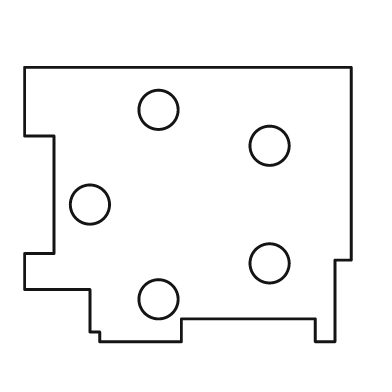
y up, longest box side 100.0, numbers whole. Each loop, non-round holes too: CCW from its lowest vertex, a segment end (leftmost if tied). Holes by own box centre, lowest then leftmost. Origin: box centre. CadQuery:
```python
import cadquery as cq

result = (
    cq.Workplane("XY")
    .moveTo(-27.0, -42.0)
    .lineTo(-2.0, -42.0)
    .lineTo(-2.0, -35.0)
    .lineTo(39.0, -35.0)
    .lineTo(39.0, -42.0)
    .lineTo(45.0, -42.0)
    .lineTo(45.0, -17.0)
    .lineTo(50.0, -17.0)
    .lineTo(50.0, 42.0)
    .lineTo(-50.0, 42.0)
    .lineTo(-50.0, 21.0)
    .lineTo(-41.0, 21.0)
    .lineTo(-41.0, -15.0)
    .lineTo(-50.0, -15.0)
    .lineTo(-50.0, -26.0)
    .lineTo(-30.0, -26.0)
    .lineTo(-30.0, -39.0)
    .lineTo(-27.0, -39.0)
    .close()
    .moveTo(-9.0, -29.0)
    .circle(6.0)
    .moveTo(25.0, -18.0)
    .circle(6.0)
    .moveTo(-30.0, 0.0)
    .circle(6.0)
    .moveTo(25.0, 18.0)
    .circle(6.0)
    .moveTo(-9.0, 29.0)
    .circle(6.0)
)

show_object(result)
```